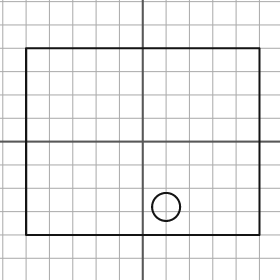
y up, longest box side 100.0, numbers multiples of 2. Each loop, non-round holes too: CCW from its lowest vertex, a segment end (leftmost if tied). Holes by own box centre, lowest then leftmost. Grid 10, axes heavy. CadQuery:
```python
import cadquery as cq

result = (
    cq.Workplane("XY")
    .moveTo(-50.0, -40.0)
    .lineTo(50.0, -40.0)
    .lineTo(50.0, 40.0)
    .lineTo(-50.0, 40.0)
    .close()
    .moveTo(10.0, -28.0)
    .circle(6.0)
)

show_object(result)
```